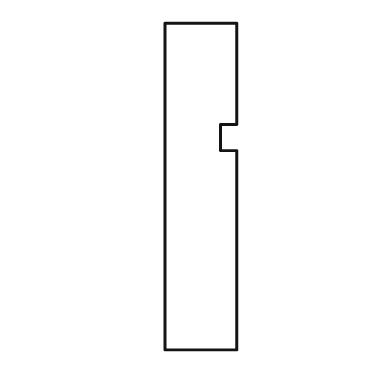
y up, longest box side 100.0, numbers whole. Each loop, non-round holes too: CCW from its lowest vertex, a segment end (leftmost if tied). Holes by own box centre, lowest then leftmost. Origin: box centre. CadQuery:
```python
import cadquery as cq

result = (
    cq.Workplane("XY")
    .moveTo(-11.0, -50.0)
    .lineTo(11.0, -50.0)
    .lineTo(11.0, 11.0)
    .lineTo(6.0, 11.0)
    .lineTo(6.0, 19.0)
    .lineTo(11.0, 19.0)
    .lineTo(11.0, 50.0)
    .lineTo(-11.0, 50.0)
    .close()
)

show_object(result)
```